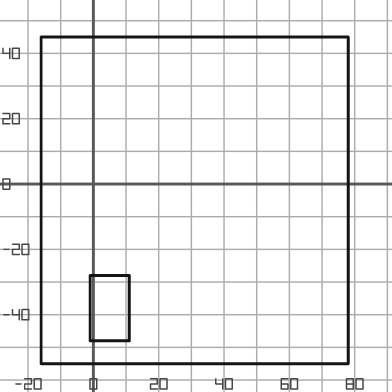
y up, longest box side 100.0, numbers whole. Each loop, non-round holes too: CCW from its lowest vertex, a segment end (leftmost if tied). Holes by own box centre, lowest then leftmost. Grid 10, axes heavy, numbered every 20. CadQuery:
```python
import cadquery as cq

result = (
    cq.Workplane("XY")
    .moveTo(-16.0, -55.0)
    .lineTo(78.0, -55.0)
    .lineTo(78.0, 45.0)
    .lineTo(-16.0, 45.0)
    .close()
    .moveTo(-1.0, -48.0)
    .lineTo(11.0, -48.0)
    .lineTo(11.0, -28.0)
    .lineTo(-1.0, -28.0)
    .close()
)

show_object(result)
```